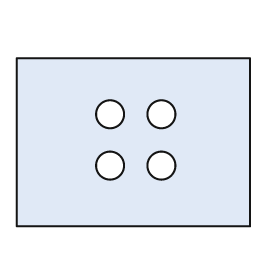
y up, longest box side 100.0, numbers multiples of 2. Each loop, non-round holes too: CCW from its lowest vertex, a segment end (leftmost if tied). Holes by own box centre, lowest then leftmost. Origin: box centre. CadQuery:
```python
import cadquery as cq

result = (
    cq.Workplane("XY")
    .moveTo(-50.0, -36.0)
    .lineTo(50.0, -36.0)
    .lineTo(50.0, 36.0)
    .lineTo(-50.0, 36.0)
    .close()
    .moveTo(-10.0, -10.0)
    .circle(6.0)
    .moveTo(12.0, -10.0)
    .circle(6.0)
    .moveTo(-10.0, 12.0)
    .circle(6.0)
    .moveTo(12.0, 12.0)
    .circle(6.0)
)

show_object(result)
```